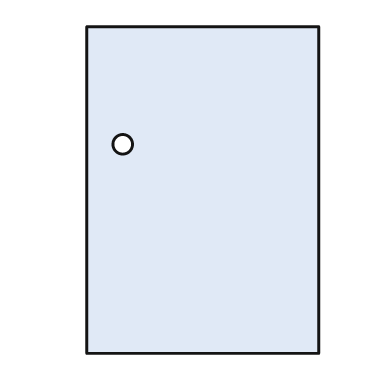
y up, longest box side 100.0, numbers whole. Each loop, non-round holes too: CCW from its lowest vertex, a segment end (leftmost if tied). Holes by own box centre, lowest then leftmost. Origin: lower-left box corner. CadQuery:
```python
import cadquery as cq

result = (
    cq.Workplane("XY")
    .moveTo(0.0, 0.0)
    .lineTo(71.0, 0.0)
    .lineTo(71.0, 100.0)
    .lineTo(0.0, 100.0)
    .close()
    .moveTo(11.0, 64.0)
    .circle(3.0)
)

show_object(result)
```